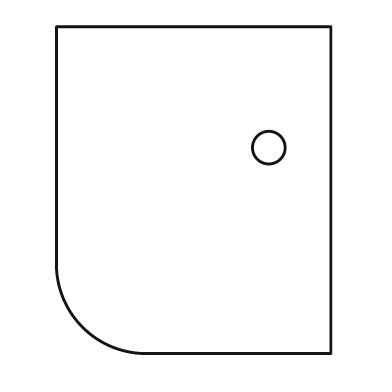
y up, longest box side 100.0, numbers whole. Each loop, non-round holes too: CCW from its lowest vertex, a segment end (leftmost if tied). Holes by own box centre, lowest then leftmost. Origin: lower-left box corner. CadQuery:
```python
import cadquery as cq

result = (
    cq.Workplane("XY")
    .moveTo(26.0, 0.0)
    .lineTo(84.0, 0.0)
    .lineTo(84.0, 100.0)
    .lineTo(0.0, 100.0)
    .lineTo(0.0, 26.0)
    .threePointArc((8.0, 8.0), (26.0, 0.0))
    .close()
    .moveTo(65.0, 63.0)
    .circle(5.0)
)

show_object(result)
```